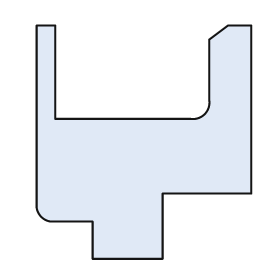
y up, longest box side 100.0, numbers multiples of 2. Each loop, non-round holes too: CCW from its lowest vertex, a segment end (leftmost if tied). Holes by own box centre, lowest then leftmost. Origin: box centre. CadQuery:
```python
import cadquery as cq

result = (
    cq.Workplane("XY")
    .moveTo(-22.0, -50.0)
    .lineTo(8.0, -50.0)
    .lineTo(8.0, -22.0)
    .lineTo(46.0, -22.0)
    .lineTo(46.0, 50.0)
    .lineTo(36.0, 50.0)
    .lineTo(28.0, 44.0)
    .lineTo(28.0, 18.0)
    .threePointArc((26.0, 12.0), (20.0, 10.0))
    .lineTo(-38.0, 10.0)
    .lineTo(-38.0, 50.0)
    .lineTo(-46.0, 50.0)
    .lineTo(-46.0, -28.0)
    .threePointArc((-44.0, -32.0), (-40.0, -34.0))
    .lineTo(-22.0, -34.0)
    .close()
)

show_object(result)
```